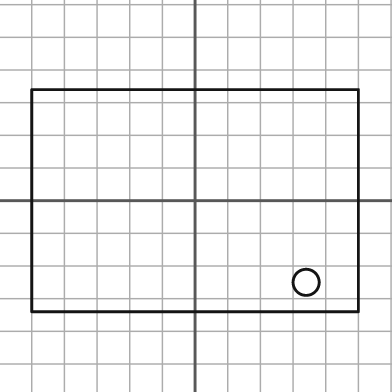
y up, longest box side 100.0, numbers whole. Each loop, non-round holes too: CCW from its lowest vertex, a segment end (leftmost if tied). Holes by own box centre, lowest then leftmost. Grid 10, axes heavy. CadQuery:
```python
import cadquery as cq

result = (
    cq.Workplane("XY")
    .moveTo(-50.0, -34.0)
    .lineTo(50.0, -34.0)
    .lineTo(50.0, 34.0)
    .lineTo(-50.0, 34.0)
    .close()
    .moveTo(34.0, -25.0)
    .circle(4.0)
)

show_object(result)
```